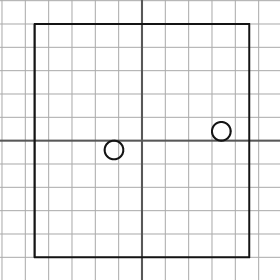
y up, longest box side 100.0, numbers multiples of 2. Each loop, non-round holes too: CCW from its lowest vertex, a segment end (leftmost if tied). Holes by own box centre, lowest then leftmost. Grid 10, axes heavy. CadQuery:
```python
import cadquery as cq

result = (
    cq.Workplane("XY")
    .moveTo(-46.0, -50.0)
    .lineTo(46.0, -50.0)
    .lineTo(46.0, 50.0)
    .lineTo(-46.0, 50.0)
    .close()
    .moveTo(-12.0, -4.0)
    .circle(4.0)
    .moveTo(34.0, 4.0)
    .circle(4.0)
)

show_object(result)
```